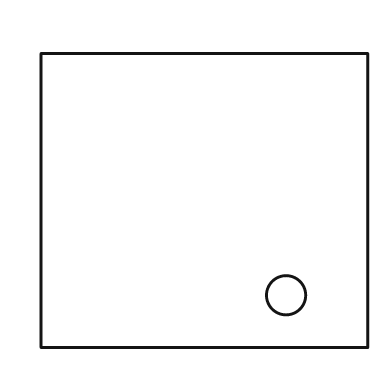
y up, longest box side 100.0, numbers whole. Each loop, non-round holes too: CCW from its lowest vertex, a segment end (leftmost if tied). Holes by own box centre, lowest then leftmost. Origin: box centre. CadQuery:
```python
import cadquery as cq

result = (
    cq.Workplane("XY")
    .moveTo(-50.0, -45.0)
    .lineTo(50.0, -45.0)
    .lineTo(50.0, 45.0)
    .lineTo(-50.0, 45.0)
    .close()
    .moveTo(25.0, -29.0)
    .circle(6.0)
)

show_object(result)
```